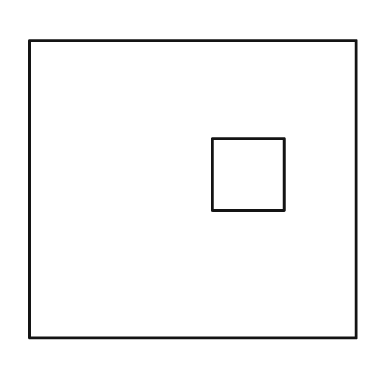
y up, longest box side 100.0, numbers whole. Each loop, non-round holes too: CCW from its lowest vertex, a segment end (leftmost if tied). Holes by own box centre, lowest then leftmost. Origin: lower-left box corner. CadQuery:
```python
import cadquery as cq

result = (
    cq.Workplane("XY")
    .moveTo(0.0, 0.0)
    .lineTo(100.0, 0.0)
    .lineTo(100.0, 91.0)
    .lineTo(0.0, 91.0)
    .close()
    .moveTo(56.0, 39.0)
    .lineTo(78.0, 39.0)
    .lineTo(78.0, 61.0)
    .lineTo(56.0, 61.0)
    .close()
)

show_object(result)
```